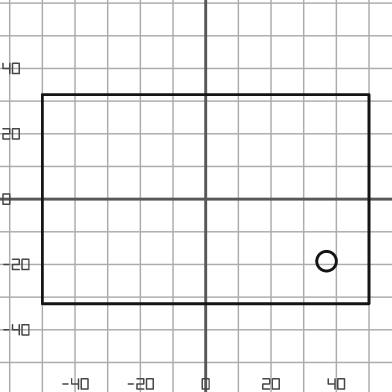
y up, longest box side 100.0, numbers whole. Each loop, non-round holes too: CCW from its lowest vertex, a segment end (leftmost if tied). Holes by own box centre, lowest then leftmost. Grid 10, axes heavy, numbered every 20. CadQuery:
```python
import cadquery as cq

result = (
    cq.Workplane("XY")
    .moveTo(-50.0, -32.0)
    .lineTo(50.0, -32.0)
    .lineTo(50.0, 32.0)
    .lineTo(-50.0, 32.0)
    .close()
    .moveTo(37.0, -19.0)
    .circle(3.0)
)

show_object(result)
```